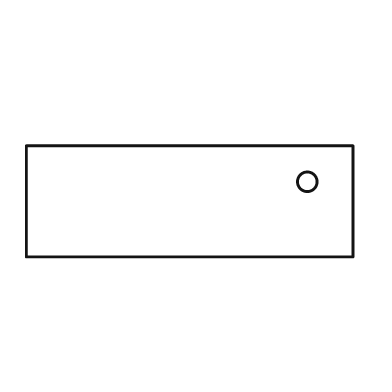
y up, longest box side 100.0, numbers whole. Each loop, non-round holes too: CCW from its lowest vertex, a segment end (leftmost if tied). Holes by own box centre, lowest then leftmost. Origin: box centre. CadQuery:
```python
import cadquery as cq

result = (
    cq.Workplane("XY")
    .moveTo(-50.0, -17.0)
    .lineTo(50.0, -17.0)
    .lineTo(50.0, 17.0)
    .lineTo(-50.0, 17.0)
    .close()
    .moveTo(36.0, 6.0)
    .circle(3.0)
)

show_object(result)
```